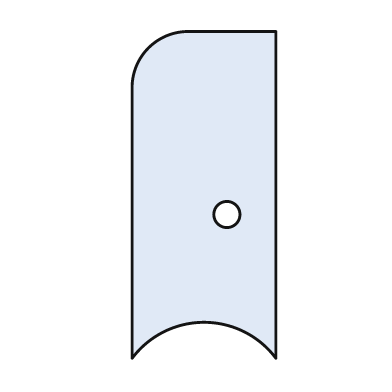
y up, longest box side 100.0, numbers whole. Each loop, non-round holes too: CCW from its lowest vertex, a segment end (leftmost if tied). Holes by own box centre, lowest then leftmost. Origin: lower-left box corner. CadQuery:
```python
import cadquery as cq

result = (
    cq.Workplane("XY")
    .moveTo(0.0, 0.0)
    .threePointArc((22.0, 11.0), (44.0, 0.0))
    .lineTo(44.0, 100.0)
    .lineTo(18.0, 100.0)
    .threePointArc((5.0, 95.0), (0.0, 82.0))
    .close()
    .moveTo(29.0, 44.0)
    .circle(4.0)
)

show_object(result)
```